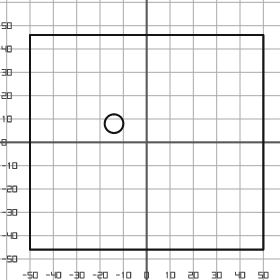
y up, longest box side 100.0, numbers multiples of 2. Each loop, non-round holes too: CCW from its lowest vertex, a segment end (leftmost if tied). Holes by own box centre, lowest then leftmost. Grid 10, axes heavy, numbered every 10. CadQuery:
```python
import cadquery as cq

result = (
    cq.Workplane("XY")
    .moveTo(-50.0, -46.0)
    .lineTo(50.0, -46.0)
    .lineTo(50.0, 46.0)
    .lineTo(-50.0, 46.0)
    .close()
    .moveTo(-14.0, 8.0)
    .circle(4.0)
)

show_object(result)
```